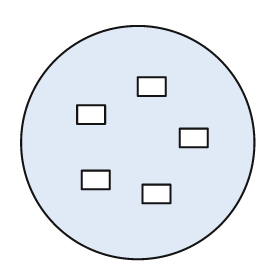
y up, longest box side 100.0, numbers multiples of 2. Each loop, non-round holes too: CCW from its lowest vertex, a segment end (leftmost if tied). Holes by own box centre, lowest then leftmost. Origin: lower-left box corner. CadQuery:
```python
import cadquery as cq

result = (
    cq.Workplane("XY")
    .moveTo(50.0, 50.0)
    .circle(50.0)
    .moveTo(52.0, 24.0)
    .lineTo(64.0, 24.0)
    .lineTo(64.0, 32.0)
    .lineTo(52.0, 32.0)
    .close()
    .moveTo(26.0, 30.0)
    .lineTo(38.0, 30.0)
    .lineTo(38.0, 38.0)
    .lineTo(26.0, 38.0)
    .close()
    .moveTo(68.0, 48.0)
    .lineTo(80.0, 48.0)
    .lineTo(80.0, 56.0)
    .lineTo(68.0, 56.0)
    .close()
    .moveTo(24.0, 58.0)
    .lineTo(36.0, 58.0)
    .lineTo(36.0, 66.0)
    .lineTo(24.0, 66.0)
    .close()
    .moveTo(50.0, 70.0)
    .lineTo(62.0, 70.0)
    .lineTo(62.0, 78.0)
    .lineTo(50.0, 78.0)
    .close()
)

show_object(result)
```